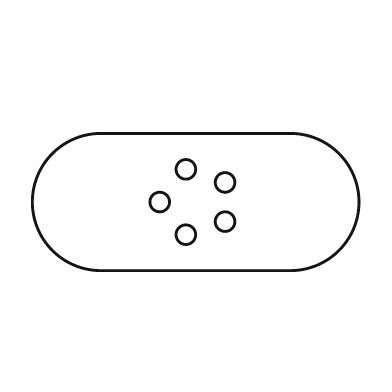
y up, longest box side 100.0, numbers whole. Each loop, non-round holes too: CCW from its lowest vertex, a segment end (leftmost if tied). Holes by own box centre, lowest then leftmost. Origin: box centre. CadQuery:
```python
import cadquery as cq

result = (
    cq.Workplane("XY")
    .moveTo(-29.0, -21.0)
    .lineTo(29.0, -21.0)
    .threePointArc((50.0, 0.0), (29.0, 21.0))
    .lineTo(-29.0, 21.0)
    .threePointArc((-50.0, 0.0), (-29.0, -21.0))
    .close()
    .moveTo(-3.0, -10.0)
    .circle(3.0)
    .moveTo(9.0, -6.0)
    .circle(3.0)
    .moveTo(-11.0, 0.0)
    .circle(3.0)
    .moveTo(9.0, 6.0)
    .circle(3.0)
    .moveTo(-3.0, 10.0)
    .circle(3.0)
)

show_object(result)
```